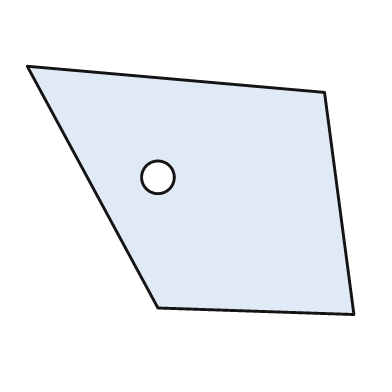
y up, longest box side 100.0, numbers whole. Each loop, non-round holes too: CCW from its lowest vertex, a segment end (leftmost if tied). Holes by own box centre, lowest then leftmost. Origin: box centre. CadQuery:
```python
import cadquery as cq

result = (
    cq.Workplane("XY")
    .moveTo(50.0, -38.0)
    .lineTo(41.0, 30.0)
    .lineTo(-50.0, 38.0)
    .lineTo(-10.0, -36.0)
    .close()
    .moveTo(-10.0, 4.0)
    .circle(5.0)
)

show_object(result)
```